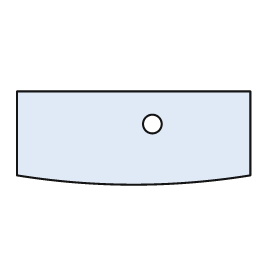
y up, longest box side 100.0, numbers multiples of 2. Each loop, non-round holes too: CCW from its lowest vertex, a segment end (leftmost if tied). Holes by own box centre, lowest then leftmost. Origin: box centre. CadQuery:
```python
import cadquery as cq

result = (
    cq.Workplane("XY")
    .moveTo(-50.0, -16.0)
    .threePointArc((0.0, -20.0), (50.0, -16.0))
    .lineTo(50.0, 20.0)
    .lineTo(-50.0, 20.0)
    .close()
    .moveTo(8.0, 6.0)
    .circle(4.0)
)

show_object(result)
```